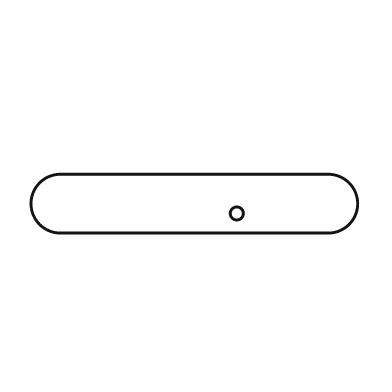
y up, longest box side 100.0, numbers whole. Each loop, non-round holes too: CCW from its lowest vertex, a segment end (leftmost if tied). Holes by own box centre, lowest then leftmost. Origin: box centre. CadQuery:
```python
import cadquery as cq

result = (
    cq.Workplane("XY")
    .moveTo(-41.0, -9.0)
    .lineTo(41.0, -9.0)
    .threePointArc((50.0, 0.0), (41.0, 9.0))
    .lineTo(-41.0, 9.0)
    .threePointArc((-50.0, 0.0), (-41.0, -9.0))
    .close()
    .moveTo(13.0, -3.0)
    .circle(2.0)
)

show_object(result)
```